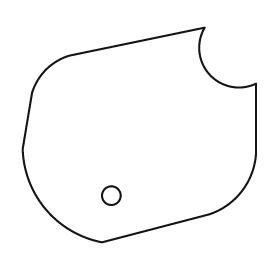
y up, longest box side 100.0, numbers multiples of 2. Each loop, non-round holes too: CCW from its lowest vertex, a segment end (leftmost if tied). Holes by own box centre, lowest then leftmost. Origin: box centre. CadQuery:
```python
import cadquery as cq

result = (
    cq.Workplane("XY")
    .moveTo(-16.0, -46.0)
    .lineTo(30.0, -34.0)
    .threePointArc((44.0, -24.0), (50.0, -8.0))
    .lineTo(50.0, 22.0)
    .threePointArc((30.0, 26.0), (28.0, 46.0))
    .lineTo(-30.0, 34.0)
    .threePointArc((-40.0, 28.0), (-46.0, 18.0))
    .lineTo(-50.0, -6.0)
    .threePointArc((-40.0, -32.0), (-16.0, -46.0))
    .close()
    .moveTo(-12.0, -26.0)
    .circle(4.0)
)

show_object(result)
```